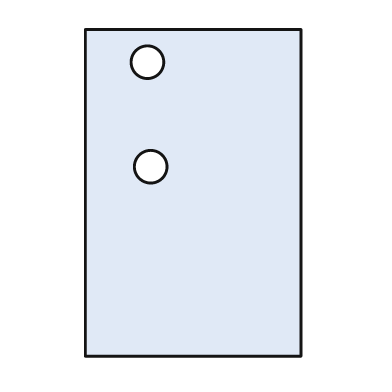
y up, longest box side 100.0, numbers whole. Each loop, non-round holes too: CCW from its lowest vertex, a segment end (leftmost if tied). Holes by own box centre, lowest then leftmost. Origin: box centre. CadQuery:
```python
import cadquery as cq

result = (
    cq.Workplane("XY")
    .moveTo(-33.0, -50.0)
    .lineTo(33.0, -50.0)
    .lineTo(33.0, 50.0)
    .lineTo(-33.0, 50.0)
    .close()
    .moveTo(-13.0, 8.0)
    .circle(5.0)
    .moveTo(-14.0, 40.0)
    .circle(5.0)
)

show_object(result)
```